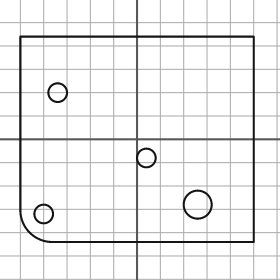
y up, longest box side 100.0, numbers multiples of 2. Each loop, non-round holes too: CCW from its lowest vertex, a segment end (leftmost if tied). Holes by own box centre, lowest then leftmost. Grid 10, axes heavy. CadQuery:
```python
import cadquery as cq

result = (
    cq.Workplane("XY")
    .moveTo(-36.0, -44.0)
    .lineTo(50.0, -44.0)
    .lineTo(50.0, 44.0)
    .lineTo(-50.0, 44.0)
    .lineTo(-50.0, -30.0)
    .threePointArc((-46.0, -40.0), (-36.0, -44.0))
    .close()
    .moveTo(-40.0, -32.0)
    .circle(4.0)
    .moveTo(26.0, -28.0)
    .circle(6.0)
    .moveTo(4.0, -8.0)
    .circle(4.0)
    .moveTo(-34.0, 20.0)
    .circle(4.0)
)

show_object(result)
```